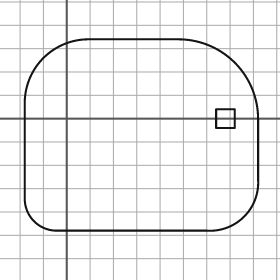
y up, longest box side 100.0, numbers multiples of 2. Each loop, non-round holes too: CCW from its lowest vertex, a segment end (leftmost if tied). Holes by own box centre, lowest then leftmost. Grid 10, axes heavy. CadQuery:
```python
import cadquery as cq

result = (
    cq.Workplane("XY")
    .moveTo(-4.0, -48.0)
    .lineTo(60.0, -48.0)
    .threePointArc((76.0, -42.0), (82.0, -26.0))
    .lineTo(82.0, 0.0)
    .threePointArc((72.0, 24.0), (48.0, 34.0))
    .lineTo(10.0, 34.0)
    .threePointArc((-10.0, 26.0), (-18.0, 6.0))
    .lineTo(-18.0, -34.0)
    .threePointArc((-14.0, -44.0), (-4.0, -48.0))
    .close()
    .moveTo(64.0, -4.0)
    .lineTo(72.0, -4.0)
    .lineTo(72.0, 4.0)
    .lineTo(64.0, 4.0)
    .close()
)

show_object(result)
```